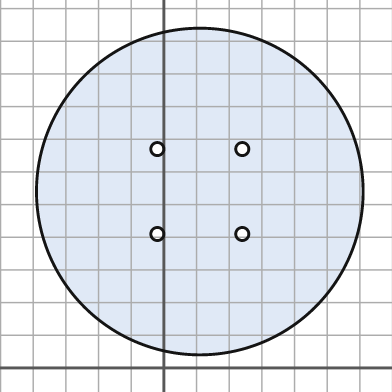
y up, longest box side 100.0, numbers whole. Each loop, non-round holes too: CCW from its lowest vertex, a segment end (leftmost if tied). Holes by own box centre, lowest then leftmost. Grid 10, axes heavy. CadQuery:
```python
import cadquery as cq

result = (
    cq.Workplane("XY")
    .moveTo(11.0, 54.0)
    .circle(50.0)
    .moveTo(-2.0, 41.0)
    .circle(2.0)
    .moveTo(24.0, 41.0)
    .circle(2.0)
    .moveTo(-2.0, 67.0)
    .circle(2.0)
    .moveTo(24.0, 67.0)
    .circle(2.0)
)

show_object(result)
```